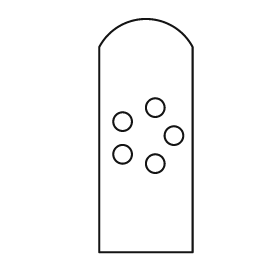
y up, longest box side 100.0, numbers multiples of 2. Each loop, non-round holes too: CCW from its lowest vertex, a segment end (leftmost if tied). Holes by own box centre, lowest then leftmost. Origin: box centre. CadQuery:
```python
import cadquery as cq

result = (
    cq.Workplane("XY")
    .moveTo(-20.0, -50.0)
    .lineTo(20.0, -50.0)
    .lineTo(20.0, 38.0)
    .threePointArc((0.0, 50.0), (-20.0, 38.0))
    .close()
    .moveTo(4.0, -12.0)
    .circle(4.0)
    .moveTo(-10.0, -8.0)
    .circle(4.0)
    .moveTo(12.0, 0.0)
    .circle(4.0)
    .moveTo(-10.0, 6.0)
    .circle(4.0)
    .moveTo(4.0, 12.0)
    .circle(4.0)
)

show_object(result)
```